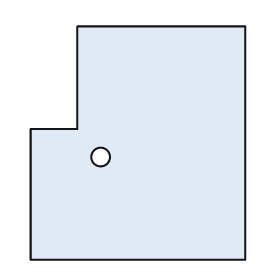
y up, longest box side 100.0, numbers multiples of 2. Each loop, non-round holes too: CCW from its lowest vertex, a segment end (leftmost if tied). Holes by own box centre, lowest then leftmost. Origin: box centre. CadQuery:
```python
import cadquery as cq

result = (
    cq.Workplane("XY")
    .moveTo(-46.0, -50.0)
    .lineTo(46.0, -50.0)
    .lineTo(46.0, 50.0)
    .lineTo(-26.0, 50.0)
    .lineTo(-26.0, 6.0)
    .lineTo(-46.0, 6.0)
    .close()
    .moveTo(-16.0, -6.0)
    .circle(4.0)
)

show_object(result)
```